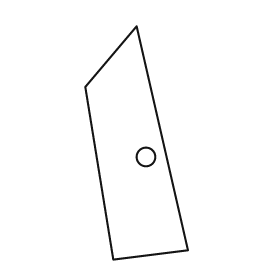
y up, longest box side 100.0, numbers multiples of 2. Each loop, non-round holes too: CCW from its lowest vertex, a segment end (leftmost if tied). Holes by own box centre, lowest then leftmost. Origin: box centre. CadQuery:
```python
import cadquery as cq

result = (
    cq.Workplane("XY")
    .moveTo(-10.0, -50.0)
    .lineTo(22.0, -46.0)
    .lineTo(0.0, 50.0)
    .lineTo(-22.0, 24.0)
    .close()
    .moveTo(4.0, -6.0)
    .circle(4.0)
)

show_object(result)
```